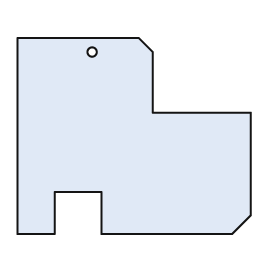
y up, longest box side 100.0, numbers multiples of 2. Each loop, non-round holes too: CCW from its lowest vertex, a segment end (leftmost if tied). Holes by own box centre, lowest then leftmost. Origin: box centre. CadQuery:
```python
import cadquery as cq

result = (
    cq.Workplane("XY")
    .moveTo(-50.0, -42.0)
    .lineTo(-34.0, -42.0)
    .lineTo(-34.0, -24.0)
    .lineTo(-14.0, -24.0)
    .lineTo(-14.0, -42.0)
    .lineTo(42.0, -42.0)
    .lineTo(50.0, -34.0)
    .lineTo(50.0, 10.0)
    .lineTo(8.0, 10.0)
    .lineTo(8.0, 36.0)
    .lineTo(2.0, 42.0)
    .lineTo(-50.0, 42.0)
    .close()
    .moveTo(-18.0, 36.0)
    .circle(2.0)
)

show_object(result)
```